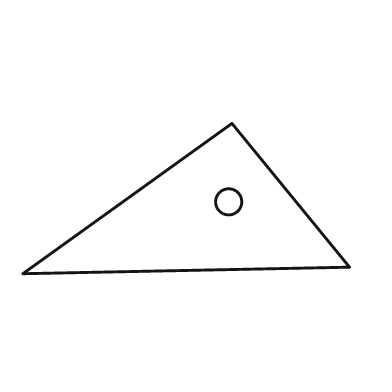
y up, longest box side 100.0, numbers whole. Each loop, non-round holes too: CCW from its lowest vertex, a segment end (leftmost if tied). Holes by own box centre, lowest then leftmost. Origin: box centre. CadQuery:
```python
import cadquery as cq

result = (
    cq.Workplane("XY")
    .moveTo(-50.0, -23.0)
    .lineTo(50.0, -21.0)
    .lineTo(14.0, 23.0)
    .close()
    .moveTo(13.0, -1.0)
    .circle(4.0)
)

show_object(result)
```